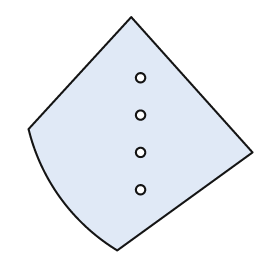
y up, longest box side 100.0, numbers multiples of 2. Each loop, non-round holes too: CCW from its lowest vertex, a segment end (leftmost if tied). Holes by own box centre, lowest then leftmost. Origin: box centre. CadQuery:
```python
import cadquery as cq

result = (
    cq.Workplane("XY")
    .moveTo(-10.0, -50.0)
    .lineTo(48.0, -8.0)
    .lineTo(-4.0, 50.0)
    .lineTo(-48.0, 2.0)
    .threePointArc((-34.0, -28.0), (-10.0, -50.0))
    .close()
    .moveTo(0.0, -24.0)
    .circle(2.0)
    .moveTo(0.0, -8.0)
    .circle(2.0)
    .moveTo(0.0, 8.0)
    .circle(2.0)
    .moveTo(0.0, 24.0)
    .circle(2.0)
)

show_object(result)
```